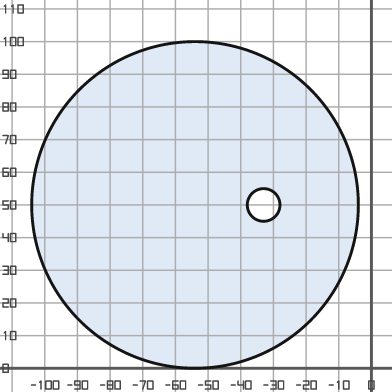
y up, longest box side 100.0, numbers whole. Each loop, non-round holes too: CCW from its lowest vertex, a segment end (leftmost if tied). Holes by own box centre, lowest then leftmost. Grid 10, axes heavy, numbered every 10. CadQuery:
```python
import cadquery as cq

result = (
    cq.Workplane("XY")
    .moveTo(-54.0, 50.0)
    .circle(50.0)
    .moveTo(-33.0, 50.0)
    .circle(5.0)
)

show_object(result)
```